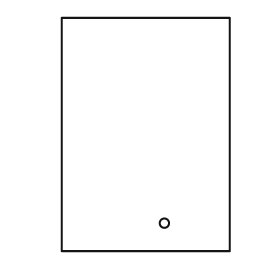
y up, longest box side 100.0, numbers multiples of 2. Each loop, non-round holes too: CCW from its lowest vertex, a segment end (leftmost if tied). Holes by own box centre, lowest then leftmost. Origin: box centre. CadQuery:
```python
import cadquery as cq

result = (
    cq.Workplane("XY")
    .moveTo(-36.0, -50.0)
    .lineTo(36.0, -50.0)
    .lineTo(36.0, 50.0)
    .lineTo(-36.0, 50.0)
    .close()
    .moveTo(8.0, -38.0)
    .circle(2.0)
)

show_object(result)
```